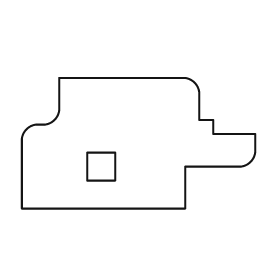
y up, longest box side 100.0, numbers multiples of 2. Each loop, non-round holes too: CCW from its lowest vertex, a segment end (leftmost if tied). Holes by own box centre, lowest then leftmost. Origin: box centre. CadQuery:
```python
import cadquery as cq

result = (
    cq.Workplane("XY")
    .moveTo(-50.0, -28.0)
    .lineTo(20.0, -28.0)
    .lineTo(20.0, -10.0)
    .lineTo(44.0, -10.0)
    .threePointArc((48.0, -8.0), (50.0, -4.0))
    .lineTo(50.0, 4.0)
    .lineTo(32.0, 4.0)
    .lineTo(32.0, 10.0)
    .lineTo(26.0, 10.0)
    .lineTo(26.0, 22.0)
    .threePointArc((24.0, 26.0), (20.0, 28.0))
    .lineTo(-34.0, 28.0)
    .lineTo(-34.0, 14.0)
    .threePointArc((-36.0, 10.0), (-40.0, 8.0))
    .lineTo(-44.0, 8.0)
    .threePointArc((-48.0, 6.0), (-50.0, 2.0))
    .close()
    .moveTo(-22.0, -16.0)
    .lineTo(-10.0, -16.0)
    .lineTo(-10.0, -4.0)
    .lineTo(-22.0, -4.0)
    .close()
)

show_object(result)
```